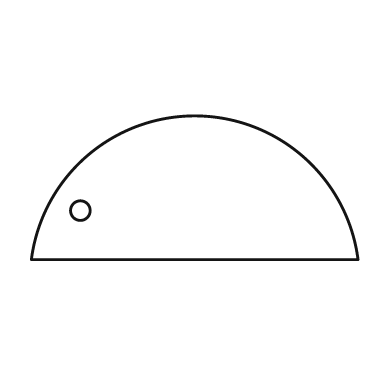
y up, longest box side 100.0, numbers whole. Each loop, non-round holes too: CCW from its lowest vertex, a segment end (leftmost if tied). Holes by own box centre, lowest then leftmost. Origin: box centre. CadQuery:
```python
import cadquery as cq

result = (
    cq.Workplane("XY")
    .moveTo(-50.0, -22.0)
    .lineTo(50.0, -22.0)
    .threePointArc((0.0, 22.0), (-50.0, -22.0))
    .close()
    .moveTo(-35.0, -7.0)
    .circle(3.0)
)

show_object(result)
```